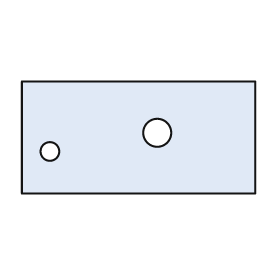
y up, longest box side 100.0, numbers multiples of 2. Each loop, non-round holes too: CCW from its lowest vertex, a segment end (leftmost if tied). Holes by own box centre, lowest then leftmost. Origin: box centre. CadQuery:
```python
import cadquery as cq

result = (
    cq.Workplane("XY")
    .moveTo(-50.0, -24.0)
    .lineTo(50.0, -24.0)
    .lineTo(50.0, 24.0)
    .lineTo(-50.0, 24.0)
    .close()
    .moveTo(-38.0, -6.0)
    .circle(4.0)
    .moveTo(8.0, 2.0)
    .circle(6.0)
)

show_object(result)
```